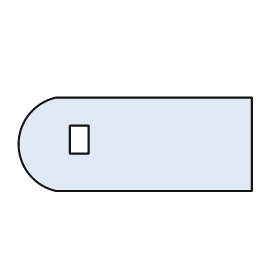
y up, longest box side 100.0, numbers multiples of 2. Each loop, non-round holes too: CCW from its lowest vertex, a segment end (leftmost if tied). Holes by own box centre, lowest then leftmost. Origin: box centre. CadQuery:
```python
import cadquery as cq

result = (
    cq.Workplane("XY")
    .moveTo(-34.0, -20.0)
    .lineTo(50.0, -20.0)
    .lineTo(50.0, 20.0)
    .lineTo(-34.0, 20.0)
    .threePointArc((-50.0, 0.0), (-34.0, -20.0))
    .close()
    .moveTo(-28.0, -4.0)
    .lineTo(-20.0, -4.0)
    .lineTo(-20.0, 8.0)
    .lineTo(-28.0, 8.0)
    .close()
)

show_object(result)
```